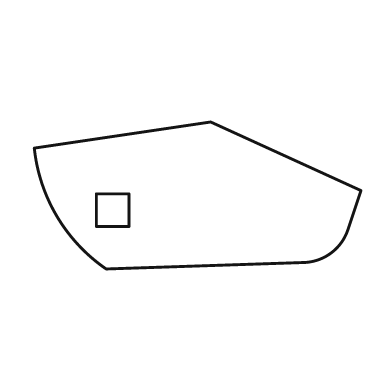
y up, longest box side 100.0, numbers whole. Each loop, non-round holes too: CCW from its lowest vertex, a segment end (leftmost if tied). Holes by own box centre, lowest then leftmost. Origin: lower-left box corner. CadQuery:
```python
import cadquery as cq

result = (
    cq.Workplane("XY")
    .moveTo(22.0, 0.0)
    .lineTo(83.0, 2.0)
    .threePointArc((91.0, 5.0), (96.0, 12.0))
    .lineTo(100.0, 24.0)
    .lineTo(54.0, 45.0)
    .lineTo(0.0, 37.0)
    .threePointArc((7.0, 16.0), (22.0, 0.0))
    .close()
    .moveTo(19.0, 13.0)
    .lineTo(29.0, 13.0)
    .lineTo(29.0, 23.0)
    .lineTo(19.0, 23.0)
    .close()
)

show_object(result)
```